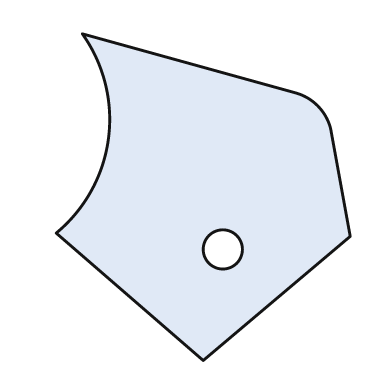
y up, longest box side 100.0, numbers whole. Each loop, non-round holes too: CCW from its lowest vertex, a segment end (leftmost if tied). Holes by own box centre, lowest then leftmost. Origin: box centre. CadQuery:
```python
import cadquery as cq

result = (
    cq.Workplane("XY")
    .moveTo(0.0, -50.0)
    .lineTo(45.0, -12.0)
    .lineTo(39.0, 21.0)
    .threePointArc((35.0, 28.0), (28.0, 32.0))
    .lineTo(-37.0, 50.0)
    .threePointArc((-29.0, 18.0), (-45.0, -11.0))
    .close()
    .moveTo(6.0, -16.0)
    .circle(6.0)
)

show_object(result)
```